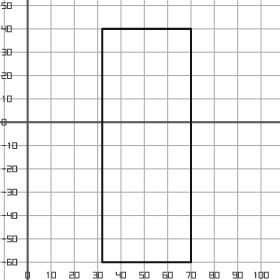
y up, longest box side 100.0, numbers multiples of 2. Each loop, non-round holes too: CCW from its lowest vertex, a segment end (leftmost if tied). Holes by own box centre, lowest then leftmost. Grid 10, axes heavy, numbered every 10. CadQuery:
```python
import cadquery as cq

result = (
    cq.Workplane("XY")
    .moveTo(32.0, -60.0)
    .lineTo(70.0, -60.0)
    .lineTo(70.0, 40.0)
    .lineTo(32.0, 40.0)
    .close()
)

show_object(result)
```